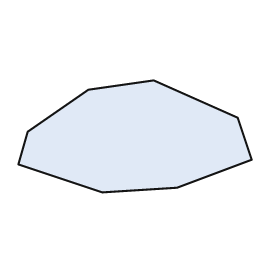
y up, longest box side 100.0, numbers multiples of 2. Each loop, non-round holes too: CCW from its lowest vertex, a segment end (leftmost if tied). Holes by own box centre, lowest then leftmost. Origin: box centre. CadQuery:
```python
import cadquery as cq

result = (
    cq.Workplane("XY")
    .moveTo(-14.0, -24.0)
    .lineTo(18.0, -22.0)
    .lineTo(50.0, -10.0)
    .lineTo(44.0, 8.0)
    .lineTo(8.0, 24.0)
    .lineTo(-20.0, 20.0)
    .lineTo(-46.0, 2.0)
    .lineTo(-50.0, -12.0)
    .close()
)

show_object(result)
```